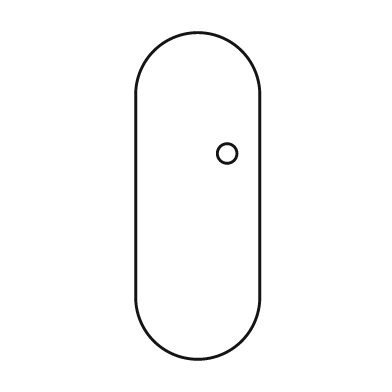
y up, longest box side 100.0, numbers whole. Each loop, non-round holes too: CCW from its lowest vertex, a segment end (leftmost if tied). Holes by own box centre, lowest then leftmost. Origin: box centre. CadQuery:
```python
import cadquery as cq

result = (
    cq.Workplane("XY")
    .moveTo(-19.0, -31.0)
    .threePointArc((0.0, -50.0), (19.0, -31.0))
    .lineTo(19.0, 31.0)
    .threePointArc((0.0, 50.0), (-19.0, 31.0))
    .close()
    .moveTo(9.0, 13.0)
    .circle(3.0)
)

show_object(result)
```